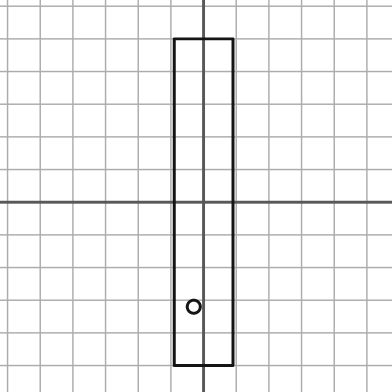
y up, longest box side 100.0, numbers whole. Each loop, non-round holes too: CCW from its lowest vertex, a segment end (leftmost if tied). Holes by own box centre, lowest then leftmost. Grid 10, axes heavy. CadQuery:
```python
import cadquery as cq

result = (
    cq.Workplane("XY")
    .moveTo(-9.0, -50.0)
    .lineTo(9.0, -50.0)
    .lineTo(9.0, 50.0)
    .lineTo(-9.0, 50.0)
    .close()
    .moveTo(-3.0, -32.0)
    .circle(2.0)
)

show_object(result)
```